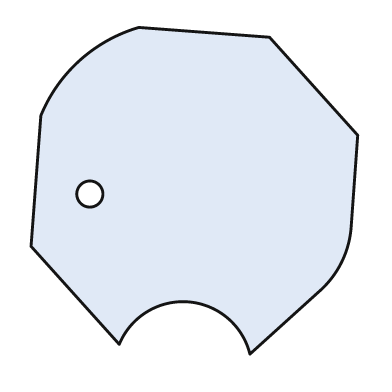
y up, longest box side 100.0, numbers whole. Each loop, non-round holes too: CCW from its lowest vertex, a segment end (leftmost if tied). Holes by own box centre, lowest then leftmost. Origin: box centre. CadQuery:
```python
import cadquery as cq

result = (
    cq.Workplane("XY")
    .moveTo(17.0, -50.0)
    .lineTo(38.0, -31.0)
    .threePointArc((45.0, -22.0), (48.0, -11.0))
    .lineTo(50.0, 17.0)
    .lineTo(23.0, 47.0)
    .lineTo(-17.0, 50.0)
    .threePointArc((-35.0, 40.0), (-47.0, 23.0))
    .lineTo(-50.0, -17.0)
    .lineTo(-23.0, -47.0)
    .threePointArc((-2.0, -34.0), (17.0, -50.0))
    .close()
    .moveTo(-32.0, -1.0)
    .circle(4.0)
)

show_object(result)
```